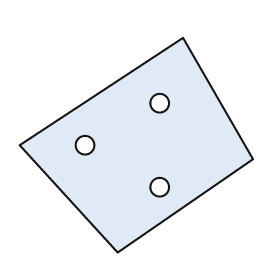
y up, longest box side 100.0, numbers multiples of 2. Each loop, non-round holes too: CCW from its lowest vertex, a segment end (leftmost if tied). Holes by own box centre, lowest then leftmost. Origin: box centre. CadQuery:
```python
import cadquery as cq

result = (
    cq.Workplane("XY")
    .moveTo(-8.0, -46.0)
    .lineTo(50.0, -6.0)
    .lineTo(20.0, 46.0)
    .lineTo(-50.0, 0.0)
    .close()
    .moveTo(10.0, -18.0)
    .circle(4.0)
    .moveTo(-22.0, 0.0)
    .circle(4.0)
    .moveTo(10.0, 18.0)
    .circle(4.0)
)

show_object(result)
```